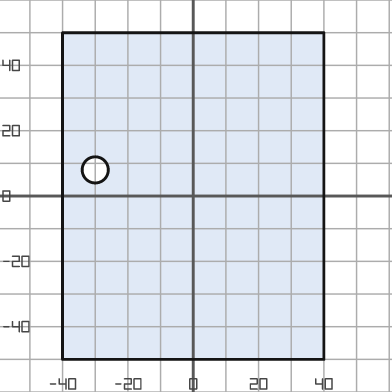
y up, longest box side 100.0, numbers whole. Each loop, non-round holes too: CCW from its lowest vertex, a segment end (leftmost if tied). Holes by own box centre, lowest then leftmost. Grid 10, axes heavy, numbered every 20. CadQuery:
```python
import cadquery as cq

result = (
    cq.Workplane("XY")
    .moveTo(-40.0, -50.0)
    .lineTo(40.0, -50.0)
    .lineTo(40.0, 50.0)
    .lineTo(-40.0, 50.0)
    .close()
    .moveTo(-30.0, 8.0)
    .circle(4.0)
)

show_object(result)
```